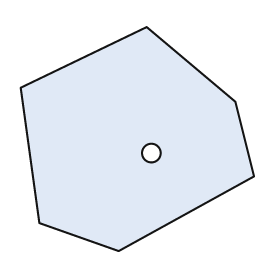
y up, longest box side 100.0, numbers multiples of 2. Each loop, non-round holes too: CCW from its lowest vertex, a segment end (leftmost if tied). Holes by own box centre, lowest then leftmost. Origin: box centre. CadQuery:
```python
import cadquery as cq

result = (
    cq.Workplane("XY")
    .moveTo(-8.0, -48.0)
    .lineTo(50.0, -16.0)
    .lineTo(42.0, 16.0)
    .lineTo(4.0, 48.0)
    .lineTo(-50.0, 22.0)
    .lineTo(-42.0, -36.0)
    .close()
    .moveTo(6.0, -6.0)
    .circle(4.0)
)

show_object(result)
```